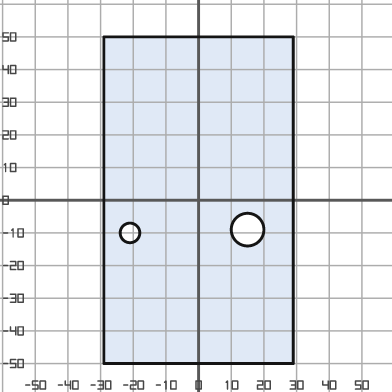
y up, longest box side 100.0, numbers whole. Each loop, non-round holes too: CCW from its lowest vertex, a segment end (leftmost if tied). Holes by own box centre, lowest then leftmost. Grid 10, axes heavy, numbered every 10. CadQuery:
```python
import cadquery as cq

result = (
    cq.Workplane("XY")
    .moveTo(-29.0, -50.0)
    .lineTo(29.0, -50.0)
    .lineTo(29.0, 50.0)
    .lineTo(-29.0, 50.0)
    .close()
    .moveTo(-21.0, -10.0)
    .circle(3.0)
    .moveTo(15.0, -9.0)
    .circle(5.0)
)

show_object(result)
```